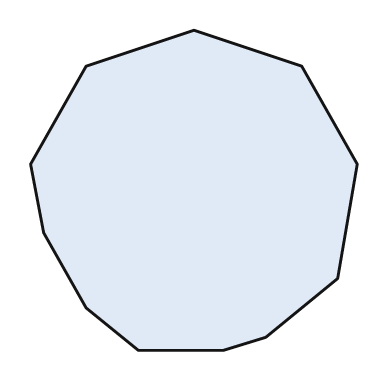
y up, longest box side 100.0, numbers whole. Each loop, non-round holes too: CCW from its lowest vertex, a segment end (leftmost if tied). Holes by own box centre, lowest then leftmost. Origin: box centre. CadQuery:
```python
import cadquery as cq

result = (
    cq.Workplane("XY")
    .moveTo(-17.0, -49.0)
    .lineTo(9.0, -49.0)
    .lineTo(22.0, -45.0)
    .lineTo(44.0, -27.0)
    .lineTo(50.0, 8.0)
    .lineTo(33.0, 38.0)
    .lineTo(0.0, 49.0)
    .lineTo(-33.0, 38.0)
    .lineTo(-50.0, 8.0)
    .lineTo(-46.0, -13.0)
    .lineTo(-33.0, -36.0)
    .close()
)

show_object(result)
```